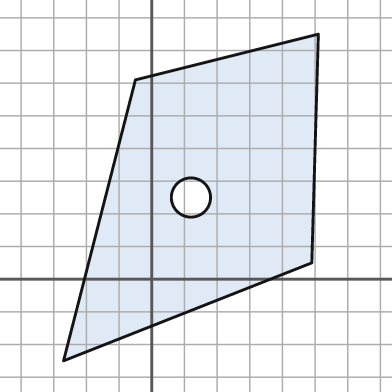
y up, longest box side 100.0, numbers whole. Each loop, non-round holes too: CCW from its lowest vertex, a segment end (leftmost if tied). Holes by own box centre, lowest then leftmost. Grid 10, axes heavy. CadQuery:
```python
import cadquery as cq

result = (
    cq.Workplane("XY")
    .moveTo(-27.0, -25.0)
    .lineTo(49.0, 5.0)
    .lineTo(51.0, 75.0)
    .lineTo(-5.0, 61.0)
    .close()
    .moveTo(12.0, 25.0)
    .circle(6.0)
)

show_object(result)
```